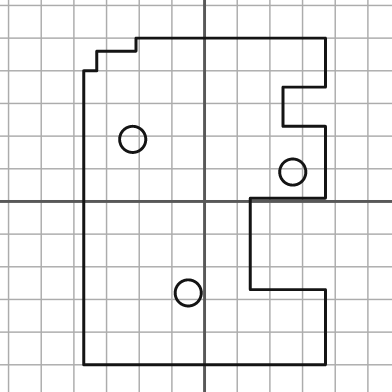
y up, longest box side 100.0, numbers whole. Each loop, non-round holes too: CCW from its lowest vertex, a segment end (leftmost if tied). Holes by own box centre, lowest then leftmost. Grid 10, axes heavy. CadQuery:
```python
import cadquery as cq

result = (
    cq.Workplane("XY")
    .moveTo(-37.0, -50.0)
    .lineTo(37.0, -50.0)
    .lineTo(37.0, -27.0)
    .lineTo(14.0, -27.0)
    .lineTo(14.0, 1.0)
    .lineTo(37.0, 1.0)
    .lineTo(37.0, 23.0)
    .lineTo(24.0, 23.0)
    .lineTo(24.0, 35.0)
    .lineTo(37.0, 35.0)
    .lineTo(37.0, 50.0)
    .lineTo(-21.0, 50.0)
    .lineTo(-21.0, 46.0)
    .lineTo(-33.0, 46.0)
    .lineTo(-33.0, 40.0)
    .lineTo(-37.0, 40.0)
    .close()
    .moveTo(-5.0, -28.0)
    .circle(4.0)
    .moveTo(27.0, 9.0)
    .circle(4.0)
    .moveTo(-22.0, 19.0)
    .circle(4.0)
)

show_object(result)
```